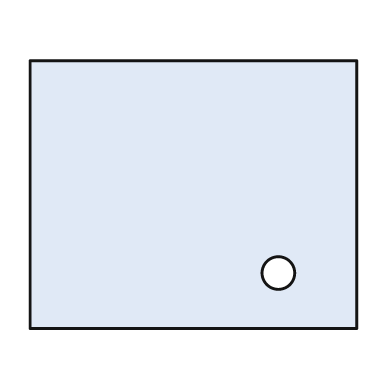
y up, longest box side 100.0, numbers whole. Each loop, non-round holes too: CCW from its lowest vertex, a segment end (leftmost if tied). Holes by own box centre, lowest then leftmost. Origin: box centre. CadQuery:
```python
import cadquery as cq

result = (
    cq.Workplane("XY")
    .moveTo(-50.0, -41.0)
    .lineTo(50.0, -41.0)
    .lineTo(50.0, 41.0)
    .lineTo(-50.0, 41.0)
    .close()
    .moveTo(26.0, -24.0)
    .circle(5.0)
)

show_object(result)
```